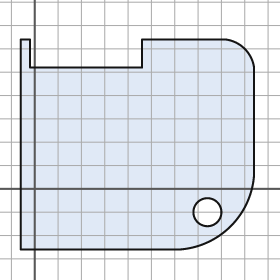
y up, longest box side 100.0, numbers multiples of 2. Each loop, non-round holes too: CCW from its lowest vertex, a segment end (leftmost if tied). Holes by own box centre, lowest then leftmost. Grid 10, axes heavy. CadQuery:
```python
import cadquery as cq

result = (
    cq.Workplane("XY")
    .moveTo(-6.0, -26.0)
    .lineTo(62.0, -26.0)
    .threePointArc((84.0, -16.0), (94.0, 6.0))
    .lineTo(94.0, 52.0)
    .threePointArc((90.0, 60.0), (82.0, 64.0))
    .lineTo(46.0, 64.0)
    .lineTo(46.0, 52.0)
    .lineTo(-2.0, 52.0)
    .lineTo(-2.0, 64.0)
    .lineTo(-6.0, 64.0)
    .close()
    .moveTo(74.0, -10.0)
    .circle(6.0)
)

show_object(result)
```